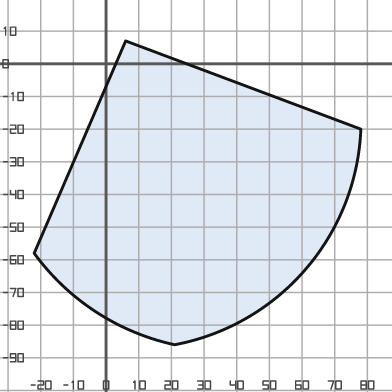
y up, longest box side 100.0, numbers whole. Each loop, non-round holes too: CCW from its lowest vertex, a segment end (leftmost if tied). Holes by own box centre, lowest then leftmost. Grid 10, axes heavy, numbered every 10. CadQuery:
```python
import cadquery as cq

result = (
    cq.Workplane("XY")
    .moveTo(21.0, -86.0)
    .threePointArc((61.0, -63.0), (78.0, -20.0))
    .lineTo(6.0, 7.0)
    .lineTo(-22.0, -58.0)
    .threePointArc((-3.0, -76.0), (21.0, -86.0))
    .close()
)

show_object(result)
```